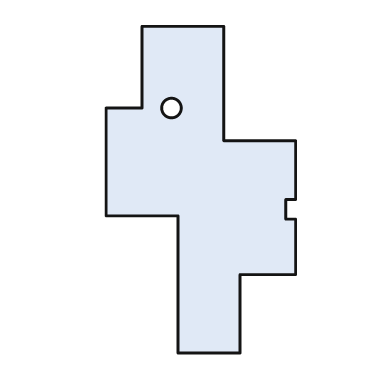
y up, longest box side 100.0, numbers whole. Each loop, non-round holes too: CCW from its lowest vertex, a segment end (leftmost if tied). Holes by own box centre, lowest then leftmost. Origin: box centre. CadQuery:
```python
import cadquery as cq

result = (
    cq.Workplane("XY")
    .moveTo(-7.0, -50.0)
    .lineTo(12.0, -50.0)
    .lineTo(12.0, -26.0)
    .lineTo(29.0, -26.0)
    .lineTo(29.0, -9.0)
    .lineTo(26.0, -9.0)
    .lineTo(26.0, -3.0)
    .lineTo(29.0, -3.0)
    .lineTo(29.0, 15.0)
    .lineTo(7.0, 15.0)
    .lineTo(7.0, 50.0)
    .lineTo(-18.0, 50.0)
    .lineTo(-18.0, 25.0)
    .lineTo(-29.0, 25.0)
    .lineTo(-29.0, -8.0)
    .lineTo(-7.0, -8.0)
    .close()
    .moveTo(-9.0, 25.0)
    .circle(3.0)
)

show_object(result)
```